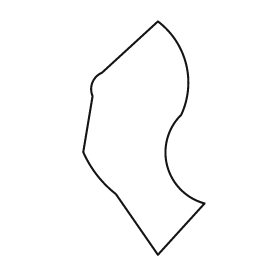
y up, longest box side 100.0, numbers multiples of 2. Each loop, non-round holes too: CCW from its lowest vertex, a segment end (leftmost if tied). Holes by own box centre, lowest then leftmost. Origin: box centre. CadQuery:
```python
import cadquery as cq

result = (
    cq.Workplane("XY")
    .moveTo(6.0, -50.0)
    .lineTo(26.0, -28.0)
    .threePointArc((10.0, -12.0), (16.0, 10.0))
    .threePointArc((18.0, 32.0), (6.0, 50.0))
    .lineTo(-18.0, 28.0)
    .threePointArc((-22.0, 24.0), (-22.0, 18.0))
    .lineTo(-26.0, -6.0)
    .threePointArc((-20.0, -16.0), (-12.0, -24.0))
    .close()
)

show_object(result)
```